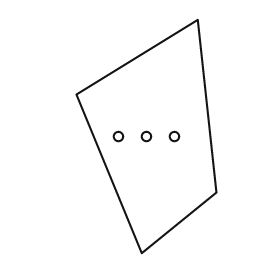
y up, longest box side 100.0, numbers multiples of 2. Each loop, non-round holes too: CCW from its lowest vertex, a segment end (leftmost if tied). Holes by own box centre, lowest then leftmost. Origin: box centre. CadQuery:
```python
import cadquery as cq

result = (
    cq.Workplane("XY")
    .moveTo(-2.0, -50.0)
    .lineTo(30.0, -24.0)
    .lineTo(22.0, 50.0)
    .lineTo(-30.0, 18.0)
    .close()
    .moveTo(-12.0, 0.0)
    .circle(2.0)
    .moveTo(0.0, 0.0)
    .circle(2.0)
    .moveTo(12.0, 0.0)
    .circle(2.0)
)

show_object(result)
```